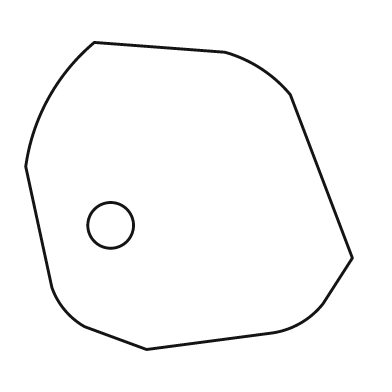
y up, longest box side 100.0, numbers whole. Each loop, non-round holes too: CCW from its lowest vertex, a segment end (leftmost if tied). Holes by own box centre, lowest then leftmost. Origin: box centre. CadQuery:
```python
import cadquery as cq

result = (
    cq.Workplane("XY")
    .moveTo(-13.0, -47.0)
    .lineTo(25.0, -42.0)
    .threePointArc((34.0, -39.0), (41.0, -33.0))
    .lineTo(50.0, -19.0)
    .lineTo(31.0, 31.0)
    .threePointArc((22.0, 39.0), (11.0, 44.0))
    .lineTo(-29.0, 47.0)
    .threePointArc((-43.0, 30.0), (-50.0, 9.0))
    .lineTo(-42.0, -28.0)
    .threePointArc((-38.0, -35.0), (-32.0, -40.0))
    .close()
    .moveTo(-24.0, -9.0)
    .circle(7.0)
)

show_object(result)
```